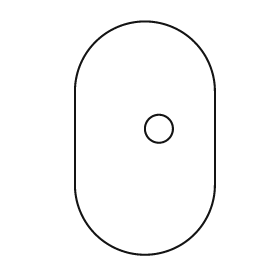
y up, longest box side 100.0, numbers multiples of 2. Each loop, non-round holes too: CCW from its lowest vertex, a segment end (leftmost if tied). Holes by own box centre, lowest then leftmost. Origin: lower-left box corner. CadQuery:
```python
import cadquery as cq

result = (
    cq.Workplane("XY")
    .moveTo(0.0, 30.0)
    .threePointArc((30.0, 0.0), (60.0, 30.0))
    .lineTo(60.0, 70.0)
    .threePointArc((30.0, 100.0), (0.0, 70.0))
    .close()
    .moveTo(36.0, 54.0)
    .circle(6.0)
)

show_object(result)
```